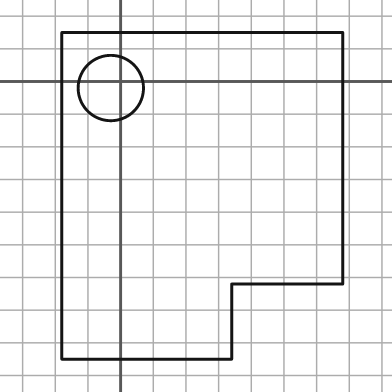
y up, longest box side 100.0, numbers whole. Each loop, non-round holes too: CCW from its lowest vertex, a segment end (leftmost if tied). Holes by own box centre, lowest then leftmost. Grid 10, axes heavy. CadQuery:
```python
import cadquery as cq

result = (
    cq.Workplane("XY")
    .moveTo(-18.0, -85.0)
    .lineTo(34.0, -85.0)
    .lineTo(34.0, -62.0)
    .lineTo(68.0, -62.0)
    .lineTo(68.0, 15.0)
    .lineTo(-18.0, 15.0)
    .close()
    .moveTo(-3.0, -2.0)
    .circle(10.0)
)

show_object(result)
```